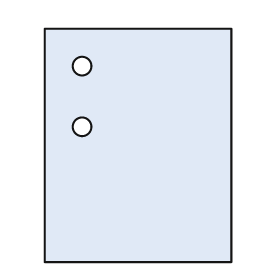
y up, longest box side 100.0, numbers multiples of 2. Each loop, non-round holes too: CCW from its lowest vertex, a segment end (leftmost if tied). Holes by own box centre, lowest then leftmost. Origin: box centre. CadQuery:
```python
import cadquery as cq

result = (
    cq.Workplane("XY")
    .moveTo(-40.0, -50.0)
    .lineTo(40.0, -50.0)
    .lineTo(40.0, 50.0)
    .lineTo(-40.0, 50.0)
    .close()
    .moveTo(-24.0, 8.0)
    .circle(4.0)
    .moveTo(-24.0, 34.0)
    .circle(4.0)
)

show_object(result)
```